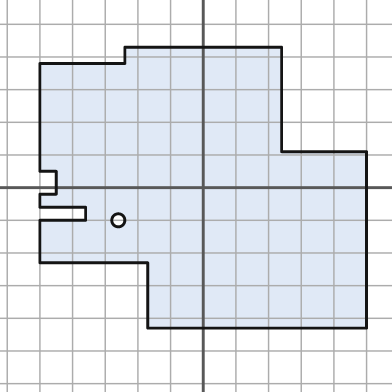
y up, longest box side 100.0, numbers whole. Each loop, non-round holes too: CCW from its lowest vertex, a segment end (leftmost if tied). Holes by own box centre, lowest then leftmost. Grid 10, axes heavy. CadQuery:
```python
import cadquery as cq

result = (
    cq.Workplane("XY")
    .moveTo(-17.0, -43.0)
    .lineTo(50.0, -43.0)
    .lineTo(50.0, 11.0)
    .lineTo(24.0, 11.0)
    .lineTo(24.0, 43.0)
    .lineTo(-24.0, 43.0)
    .lineTo(-24.0, 38.0)
    .lineTo(-50.0, 38.0)
    .lineTo(-50.0, 5.0)
    .lineTo(-45.0, 5.0)
    .lineTo(-45.0, -2.0)
    .lineTo(-50.0, -2.0)
    .lineTo(-50.0, -6.0)
    .lineTo(-36.0, -6.0)
    .lineTo(-36.0, -10.0)
    .lineTo(-50.0, -10.0)
    .lineTo(-50.0, -23.0)
    .lineTo(-17.0, -23.0)
    .close()
    .moveTo(-26.0, -10.0)
    .circle(2.0)
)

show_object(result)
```